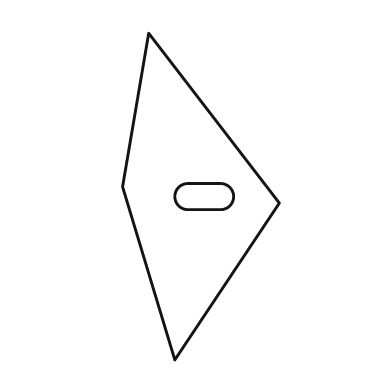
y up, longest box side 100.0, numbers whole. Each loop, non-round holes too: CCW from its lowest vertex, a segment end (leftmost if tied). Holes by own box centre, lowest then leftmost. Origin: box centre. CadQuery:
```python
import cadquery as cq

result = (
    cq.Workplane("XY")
    .moveTo(-8.0, -50.0)
    .lineTo(24.0, -2.0)
    .lineTo(-16.0, 50.0)
    .lineTo(-24.0, 3.0)
    .close()
    .moveTo(-4.0, -4.0)
    .lineTo(6.0, -4.0)
    .threePointArc((10.0, 0.0), (6.0, 4.0))
    .lineTo(-4.0, 4.0)
    .threePointArc((-8.0, 0.0), (-4.0, -4.0))
    .close()
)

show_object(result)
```